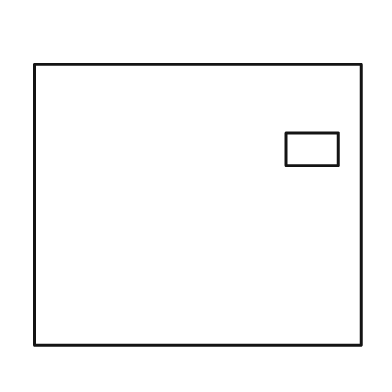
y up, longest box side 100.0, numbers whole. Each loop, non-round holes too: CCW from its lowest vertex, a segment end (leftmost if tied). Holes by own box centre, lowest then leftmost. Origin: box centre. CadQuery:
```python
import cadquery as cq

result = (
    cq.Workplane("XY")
    .moveTo(-50.0, -43.0)
    .lineTo(50.0, -43.0)
    .lineTo(50.0, 43.0)
    .lineTo(-50.0, 43.0)
    .close()
    .moveTo(27.0, 12.0)
    .lineTo(43.0, 12.0)
    .lineTo(43.0, 22.0)
    .lineTo(27.0, 22.0)
    .close()
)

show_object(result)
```